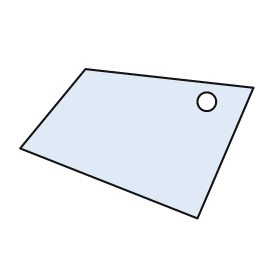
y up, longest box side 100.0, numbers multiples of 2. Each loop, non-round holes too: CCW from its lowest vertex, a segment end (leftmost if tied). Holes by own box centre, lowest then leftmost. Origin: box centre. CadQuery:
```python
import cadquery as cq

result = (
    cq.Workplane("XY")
    .moveTo(26.0, -32.0)
    .lineTo(50.0, 24.0)
    .lineTo(-22.0, 32.0)
    .lineTo(-50.0, -2.0)
    .close()
    .moveTo(30.0, 18.0)
    .circle(4.0)
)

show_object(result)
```